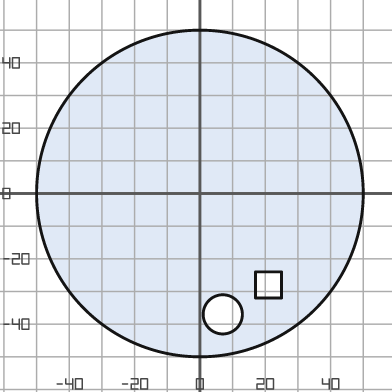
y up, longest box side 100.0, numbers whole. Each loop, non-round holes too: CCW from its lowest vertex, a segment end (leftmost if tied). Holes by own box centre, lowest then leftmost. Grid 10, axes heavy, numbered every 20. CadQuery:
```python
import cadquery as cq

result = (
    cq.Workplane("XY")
    .moveTo(0.0, 0.0)
    .circle(50.0)
    .moveTo(7.0, -37.0)
    .circle(6.0)
    .moveTo(17.0, -32.0)
    .lineTo(25.0, -32.0)
    .lineTo(25.0, -24.0)
    .lineTo(17.0, -24.0)
    .close()
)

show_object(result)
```